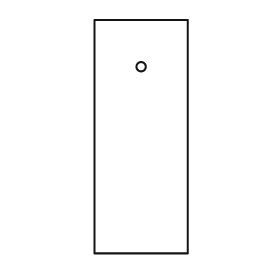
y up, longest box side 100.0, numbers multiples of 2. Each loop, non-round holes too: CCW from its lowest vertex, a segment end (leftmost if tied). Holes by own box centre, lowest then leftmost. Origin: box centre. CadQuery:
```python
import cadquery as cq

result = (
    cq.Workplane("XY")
    .moveTo(-20.0, -50.0)
    .lineTo(20.0, -50.0)
    .lineTo(20.0, 50.0)
    .lineTo(-20.0, 50.0)
    .close()
    .moveTo(0.0, 30.0)
    .circle(2.0)
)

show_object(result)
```